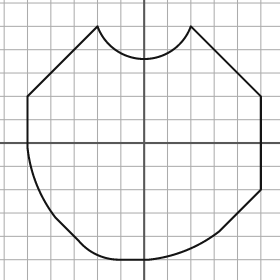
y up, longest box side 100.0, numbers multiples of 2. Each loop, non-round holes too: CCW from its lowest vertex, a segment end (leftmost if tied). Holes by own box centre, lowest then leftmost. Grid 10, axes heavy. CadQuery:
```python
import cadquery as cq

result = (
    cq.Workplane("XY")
    .moveTo(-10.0, -50.0)
    .lineTo(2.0, -50.0)
    .threePointArc((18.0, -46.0), (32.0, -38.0))
    .lineTo(50.0, -20.0)
    .lineTo(50.0, 20.0)
    .lineTo(20.0, 50.0)
    .threePointArc((0.0, 36.0), (-20.0, 50.0))
    .lineTo(-50.0, 20.0)
    .lineTo(-50.0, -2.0)
    .threePointArc((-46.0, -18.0), (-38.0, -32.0))
    .lineTo(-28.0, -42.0)
    .threePointArc((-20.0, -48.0), (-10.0, -50.0))
    .close()
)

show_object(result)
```